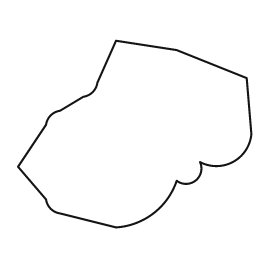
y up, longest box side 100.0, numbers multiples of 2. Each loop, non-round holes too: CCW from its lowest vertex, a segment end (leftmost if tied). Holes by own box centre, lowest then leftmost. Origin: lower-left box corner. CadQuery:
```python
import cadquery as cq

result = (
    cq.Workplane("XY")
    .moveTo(42.0, 0.0)
    .threePointArc((58.0, 6.0), (68.0, 20.0))
    .threePointArc((76.0, 20.0), (78.0, 28.0))
    .threePointArc((92.0, 28.0), (100.0, 40.0))
    .lineTo(98.0, 64.0)
    .lineTo(68.0, 76.0)
    .lineTo(42.0, 80.0)
    .lineTo(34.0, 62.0)
    .threePointArc((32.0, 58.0), (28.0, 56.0))
    .lineTo(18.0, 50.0)
    .threePointArc((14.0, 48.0), (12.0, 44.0))
    .lineTo(0.0, 26.0)
    .lineTo(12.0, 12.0)
    .threePointArc((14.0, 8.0), (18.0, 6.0))
    .close()
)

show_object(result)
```